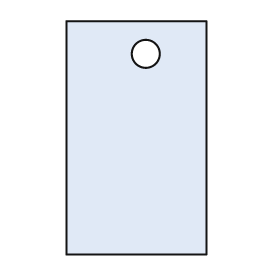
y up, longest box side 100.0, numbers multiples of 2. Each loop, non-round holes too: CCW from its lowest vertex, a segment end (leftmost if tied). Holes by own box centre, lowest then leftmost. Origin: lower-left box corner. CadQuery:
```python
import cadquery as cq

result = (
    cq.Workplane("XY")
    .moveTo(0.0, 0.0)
    .lineTo(60.0, 0.0)
    .lineTo(60.0, 100.0)
    .lineTo(0.0, 100.0)
    .close()
    .moveTo(34.0, 86.0)
    .circle(6.0)
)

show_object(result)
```